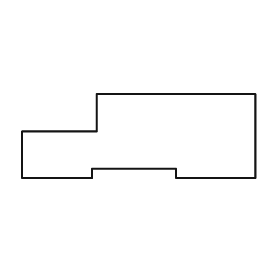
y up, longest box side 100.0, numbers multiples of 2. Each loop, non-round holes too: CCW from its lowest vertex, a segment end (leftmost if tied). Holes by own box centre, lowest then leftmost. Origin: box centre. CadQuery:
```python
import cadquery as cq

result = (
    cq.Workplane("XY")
    .moveTo(-50.0, -18.0)
    .lineTo(-20.0, -18.0)
    .lineTo(-20.0, -14.0)
    .lineTo(16.0, -14.0)
    .lineTo(16.0, -18.0)
    .lineTo(50.0, -18.0)
    .lineTo(50.0, 18.0)
    .lineTo(-18.0, 18.0)
    .lineTo(-18.0, 2.0)
    .lineTo(-50.0, 2.0)
    .close()
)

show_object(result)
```